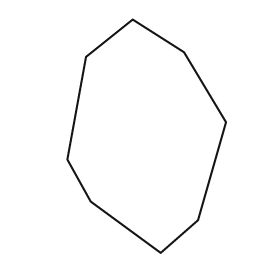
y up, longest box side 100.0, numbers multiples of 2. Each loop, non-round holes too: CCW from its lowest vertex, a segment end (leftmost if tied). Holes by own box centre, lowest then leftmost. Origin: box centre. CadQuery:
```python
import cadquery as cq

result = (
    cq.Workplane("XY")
    .moveTo(6.0, -50.0)
    .lineTo(22.0, -36.0)
    .lineTo(34.0, 6.0)
    .lineTo(16.0, 36.0)
    .lineTo(-6.0, 50.0)
    .lineTo(-26.0, 34.0)
    .lineTo(-34.0, -10.0)
    .lineTo(-24.0, -28.0)
    .close()
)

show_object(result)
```